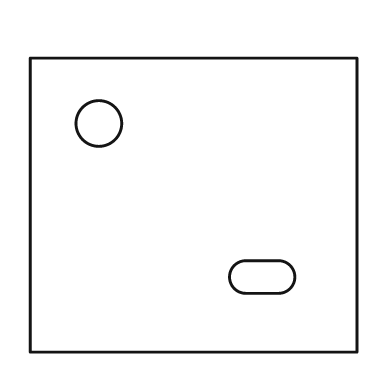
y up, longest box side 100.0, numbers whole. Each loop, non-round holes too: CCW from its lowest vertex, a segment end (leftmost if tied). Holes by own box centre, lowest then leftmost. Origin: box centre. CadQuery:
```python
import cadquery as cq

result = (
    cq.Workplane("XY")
    .moveTo(-50.0, -45.0)
    .lineTo(50.0, -45.0)
    .lineTo(50.0, 45.0)
    .lineTo(-50.0, 45.0)
    .close()
    .moveTo(16.0, -27.0)
    .lineTo(26.0, -27.0)
    .threePointArc((31.0, -22.0), (26.0, -17.0))
    .lineTo(16.0, -17.0)
    .threePointArc((11.0, -22.0), (16.0, -27.0))
    .close()
    .moveTo(-29.0, 25.0)
    .circle(7.0)
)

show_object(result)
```